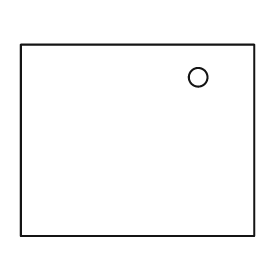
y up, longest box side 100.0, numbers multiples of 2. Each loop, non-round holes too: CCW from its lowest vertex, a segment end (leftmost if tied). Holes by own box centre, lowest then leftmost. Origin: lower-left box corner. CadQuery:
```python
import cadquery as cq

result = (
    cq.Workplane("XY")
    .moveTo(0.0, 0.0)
    .lineTo(100.0, 0.0)
    .lineTo(100.0, 82.0)
    .lineTo(0.0, 82.0)
    .close()
    .moveTo(76.0, 68.0)
    .circle(4.0)
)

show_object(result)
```